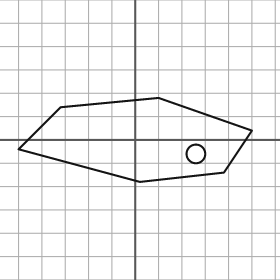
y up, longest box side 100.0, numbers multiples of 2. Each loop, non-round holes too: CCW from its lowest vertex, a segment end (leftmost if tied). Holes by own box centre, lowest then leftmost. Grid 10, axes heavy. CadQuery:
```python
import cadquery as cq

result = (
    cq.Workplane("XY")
    .moveTo(2.0, -18.0)
    .lineTo(38.0, -14.0)
    .lineTo(50.0, 4.0)
    .lineTo(10.0, 18.0)
    .lineTo(-32.0, 14.0)
    .lineTo(-50.0, -4.0)
    .close()
    .moveTo(26.0, -6.0)
    .circle(4.0)
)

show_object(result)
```